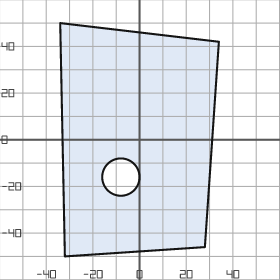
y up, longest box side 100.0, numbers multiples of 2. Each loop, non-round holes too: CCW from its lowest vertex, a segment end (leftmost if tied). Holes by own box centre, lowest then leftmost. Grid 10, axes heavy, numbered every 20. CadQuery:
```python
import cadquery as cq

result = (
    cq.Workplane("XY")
    .moveTo(-32.0, -50.0)
    .lineTo(28.0, -46.0)
    .lineTo(34.0, 42.0)
    .lineTo(-34.0, 50.0)
    .close()
    .moveTo(-8.0, -16.0)
    .circle(8.0)
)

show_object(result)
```